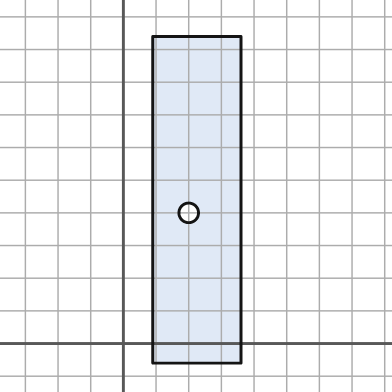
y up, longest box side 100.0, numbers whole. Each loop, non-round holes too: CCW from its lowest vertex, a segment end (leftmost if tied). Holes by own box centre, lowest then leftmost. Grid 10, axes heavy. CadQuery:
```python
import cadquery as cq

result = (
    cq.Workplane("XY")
    .moveTo(9.0, -6.0)
    .lineTo(36.0, -6.0)
    .lineTo(36.0, 94.0)
    .lineTo(9.0, 94.0)
    .close()
    .moveTo(20.0, 40.0)
    .circle(3.0)
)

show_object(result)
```